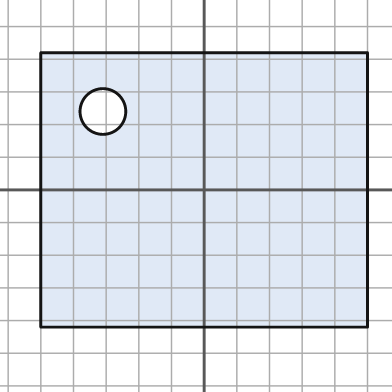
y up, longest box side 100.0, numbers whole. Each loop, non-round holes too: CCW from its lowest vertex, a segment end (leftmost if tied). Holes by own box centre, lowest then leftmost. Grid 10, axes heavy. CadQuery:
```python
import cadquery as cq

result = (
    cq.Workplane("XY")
    .moveTo(-50.0, -42.0)
    .lineTo(50.0, -42.0)
    .lineTo(50.0, 42.0)
    .lineTo(-50.0, 42.0)
    .close()
    .moveTo(-31.0, 24.0)
    .circle(7.0)
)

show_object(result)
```